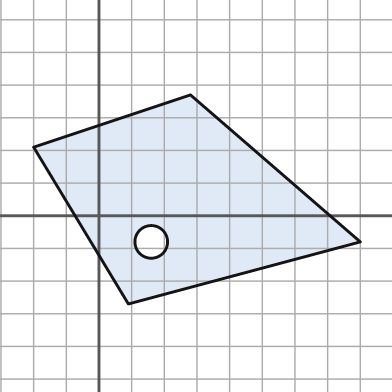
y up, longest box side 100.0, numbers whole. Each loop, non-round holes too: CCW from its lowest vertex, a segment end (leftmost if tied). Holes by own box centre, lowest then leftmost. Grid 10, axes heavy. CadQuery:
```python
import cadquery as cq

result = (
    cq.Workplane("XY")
    .moveTo(9.0, -27.0)
    .lineTo(80.0, -8.0)
    .lineTo(28.0, 37.0)
    .lineTo(-20.0, 21.0)
    .close()
    .moveTo(16.0, -8.0)
    .circle(5.0)
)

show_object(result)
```